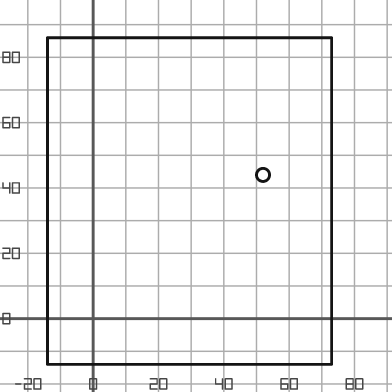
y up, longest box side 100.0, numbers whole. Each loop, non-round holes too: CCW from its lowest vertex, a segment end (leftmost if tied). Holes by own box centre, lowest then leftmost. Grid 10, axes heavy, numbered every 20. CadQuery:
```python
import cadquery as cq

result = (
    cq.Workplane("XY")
    .moveTo(-14.0, -14.0)
    .lineTo(73.0, -14.0)
    .lineTo(73.0, 86.0)
    .lineTo(-14.0, 86.0)
    .close()
    .moveTo(52.0, 44.0)
    .circle(2.0)
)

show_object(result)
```